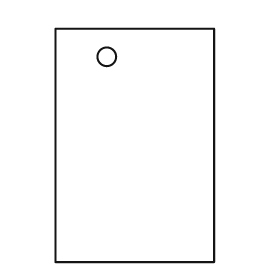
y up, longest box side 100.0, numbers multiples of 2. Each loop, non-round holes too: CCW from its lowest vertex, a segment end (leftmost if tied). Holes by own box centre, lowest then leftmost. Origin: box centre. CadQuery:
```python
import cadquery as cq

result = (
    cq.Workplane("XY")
    .moveTo(-34.0, -50.0)
    .lineTo(34.0, -50.0)
    .lineTo(34.0, 50.0)
    .lineTo(-34.0, 50.0)
    .close()
    .moveTo(-12.0, 38.0)
    .circle(4.0)
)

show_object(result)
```